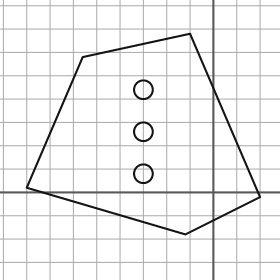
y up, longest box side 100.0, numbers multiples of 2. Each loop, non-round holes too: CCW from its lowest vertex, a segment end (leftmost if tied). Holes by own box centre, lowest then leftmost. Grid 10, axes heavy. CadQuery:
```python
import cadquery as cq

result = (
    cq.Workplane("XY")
    .moveTo(-12.0, -18.0)
    .lineTo(20.0, -2.0)
    .lineTo(-10.0, 68.0)
    .lineTo(-56.0, 58.0)
    .lineTo(-80.0, 2.0)
    .close()
    .moveTo(-30.0, 8.0)
    .circle(4.0)
    .moveTo(-30.0, 26.0)
    .circle(4.0)
    .moveTo(-30.0, 44.0)
    .circle(4.0)
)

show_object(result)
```